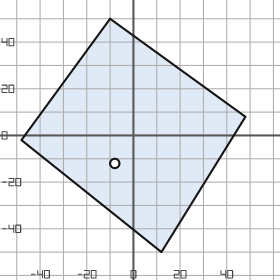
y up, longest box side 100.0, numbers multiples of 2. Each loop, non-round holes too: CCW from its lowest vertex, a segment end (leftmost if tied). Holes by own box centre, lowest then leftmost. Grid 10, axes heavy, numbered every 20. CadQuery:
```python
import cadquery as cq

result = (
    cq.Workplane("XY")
    .moveTo(12.0, -50.0)
    .lineTo(48.0, 8.0)
    .lineTo(-10.0, 50.0)
    .lineTo(-48.0, -2.0)
    .close()
    .moveTo(-8.0, -12.0)
    .circle(2.0)
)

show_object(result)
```